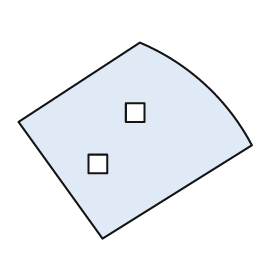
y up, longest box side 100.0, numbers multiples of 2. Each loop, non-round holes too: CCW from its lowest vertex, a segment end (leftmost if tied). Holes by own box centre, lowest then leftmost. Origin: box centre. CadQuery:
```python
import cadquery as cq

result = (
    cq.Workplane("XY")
    .moveTo(-14.0, -42.0)
    .lineTo(50.0, -2.0)
    .threePointArc((30.0, 24.0), (2.0, 42.0))
    .lineTo(-50.0, 8.0)
    .close()
    .moveTo(-20.0, -14.0)
    .lineTo(-12.0, -14.0)
    .lineTo(-12.0, -6.0)
    .lineTo(-20.0, -6.0)
    .close()
    .moveTo(-4.0, 8.0)
    .lineTo(4.0, 8.0)
    .lineTo(4.0, 16.0)
    .lineTo(-4.0, 16.0)
    .close()
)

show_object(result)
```